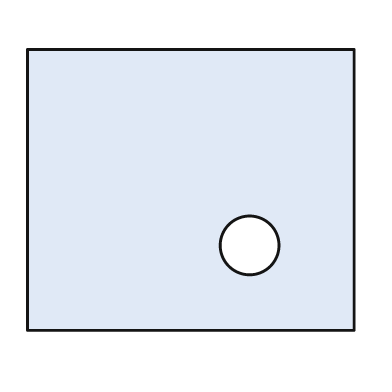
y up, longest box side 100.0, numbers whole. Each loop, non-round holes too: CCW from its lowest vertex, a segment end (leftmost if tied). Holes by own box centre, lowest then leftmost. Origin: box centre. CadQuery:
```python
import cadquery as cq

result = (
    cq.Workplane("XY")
    .moveTo(-50.0, -43.0)
    .lineTo(50.0, -43.0)
    .lineTo(50.0, 43.0)
    .lineTo(-50.0, 43.0)
    .close()
    .moveTo(18.0, -17.0)
    .circle(9.0)
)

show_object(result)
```